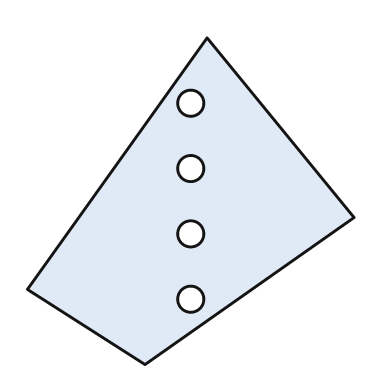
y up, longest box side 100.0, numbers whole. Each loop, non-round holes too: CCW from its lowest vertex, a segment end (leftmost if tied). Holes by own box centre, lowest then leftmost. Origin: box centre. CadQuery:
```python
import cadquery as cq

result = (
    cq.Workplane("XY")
    .moveTo(-14.0, -50.0)
    .lineTo(50.0, -5.0)
    .lineTo(5.0, 50.0)
    .lineTo(-50.0, -27.0)
    .close()
    .moveTo(0.0, -30.0)
    .circle(4.0)
    .moveTo(0.0, -10.0)
    .circle(4.0)
    .moveTo(0.0, 10.0)
    .circle(4.0)
    .moveTo(0.0, 30.0)
    .circle(4.0)
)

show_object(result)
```